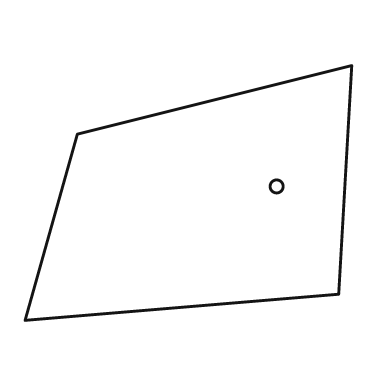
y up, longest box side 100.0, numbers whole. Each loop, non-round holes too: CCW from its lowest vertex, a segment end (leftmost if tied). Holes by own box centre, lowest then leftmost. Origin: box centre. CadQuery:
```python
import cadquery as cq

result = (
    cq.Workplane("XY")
    .moveTo(-50.0, -39.0)
    .lineTo(46.0, -31.0)
    .lineTo(50.0, 39.0)
    .lineTo(-34.0, 18.0)
    .close()
    .moveTo(27.0, 2.0)
    .circle(2.0)
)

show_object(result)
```